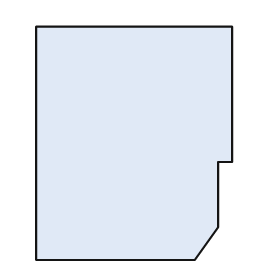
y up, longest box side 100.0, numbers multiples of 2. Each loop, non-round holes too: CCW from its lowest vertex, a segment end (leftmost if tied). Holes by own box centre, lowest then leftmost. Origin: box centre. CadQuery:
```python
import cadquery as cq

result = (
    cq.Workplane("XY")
    .moveTo(-42.0, -50.0)
    .lineTo(26.0, -50.0)
    .lineTo(36.0, -36.0)
    .lineTo(36.0, -8.0)
    .lineTo(42.0, -8.0)
    .lineTo(42.0, 50.0)
    .lineTo(-42.0, 50.0)
    .close()
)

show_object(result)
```